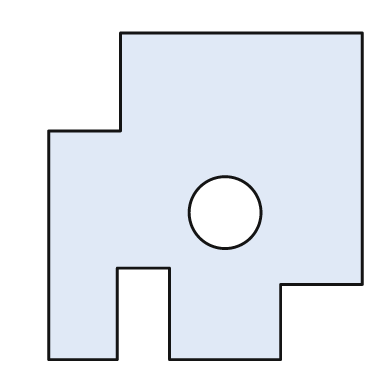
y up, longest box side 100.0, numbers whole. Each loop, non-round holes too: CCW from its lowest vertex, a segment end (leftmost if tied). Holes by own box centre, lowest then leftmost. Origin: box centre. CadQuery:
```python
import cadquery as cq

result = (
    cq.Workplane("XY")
    .moveTo(-48.0, -50.0)
    .lineTo(-27.0, -50.0)
    .lineTo(-27.0, -22.0)
    .lineTo(-11.0, -22.0)
    .lineTo(-11.0, -50.0)
    .lineTo(23.0, -50.0)
    .lineTo(23.0, -27.0)
    .lineTo(48.0, -27.0)
    .lineTo(48.0, 50.0)
    .lineTo(-26.0, 50.0)
    .lineTo(-26.0, 20.0)
    .lineTo(-48.0, 20.0)
    .close()
    .moveTo(6.0, -5.0)
    .circle(11.0)
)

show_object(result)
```